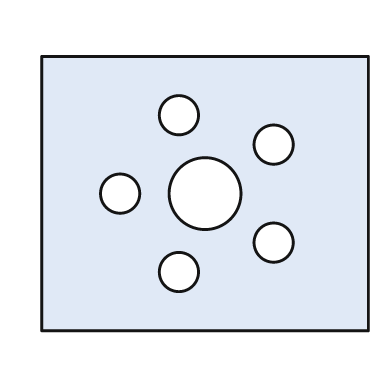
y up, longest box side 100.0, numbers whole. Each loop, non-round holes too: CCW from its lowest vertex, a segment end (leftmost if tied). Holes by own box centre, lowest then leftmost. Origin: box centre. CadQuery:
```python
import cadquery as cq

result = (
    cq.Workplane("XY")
    .moveTo(-50.0, -42.0)
    .lineTo(50.0, -42.0)
    .lineTo(50.0, 42.0)
    .lineTo(-50.0, 42.0)
    .close()
    .moveTo(-8.0, -24.0)
    .circle(6.0)
    .moveTo(21.0, -15.0)
    .circle(6.0)
    .moveTo(-26.0, 0.0)
    .circle(6.0)
    .moveTo(0.0, 0.0)
    .circle(11.0)
    .moveTo(21.0, 15.0)
    .circle(6.0)
    .moveTo(-8.0, 24.0)
    .circle(6.0)
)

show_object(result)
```